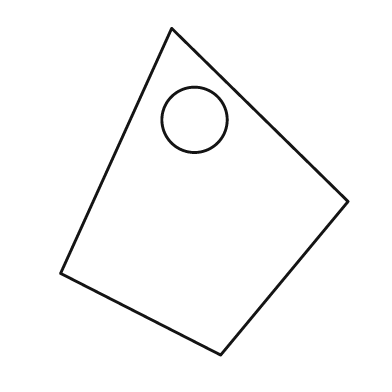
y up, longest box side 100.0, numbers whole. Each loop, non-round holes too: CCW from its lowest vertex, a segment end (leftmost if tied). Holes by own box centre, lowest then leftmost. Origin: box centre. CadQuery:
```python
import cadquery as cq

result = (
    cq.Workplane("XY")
    .moveTo(5.0, -50.0)
    .lineTo(44.0, -3.0)
    .lineTo(-10.0, 50.0)
    .lineTo(-44.0, -25.0)
    .close()
    .moveTo(-3.0, 22.0)
    .circle(10.0)
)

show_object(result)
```